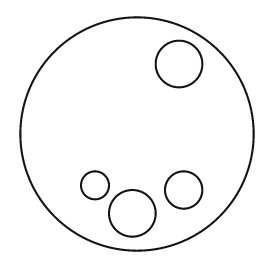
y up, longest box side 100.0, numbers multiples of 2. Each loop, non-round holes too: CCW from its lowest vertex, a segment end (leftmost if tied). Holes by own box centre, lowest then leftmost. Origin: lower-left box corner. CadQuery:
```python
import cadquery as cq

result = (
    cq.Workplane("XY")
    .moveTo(50.0, 50.0)
    .circle(50.0)
    .moveTo(48.0, 16.0)
    .circle(10.0)
    .moveTo(70.0, 26.0)
    .circle(8.0)
    .moveTo(32.0, 28.0)
    .circle(6.0)
    .moveTo(68.0, 80.0)
    .circle(10.0)
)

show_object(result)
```